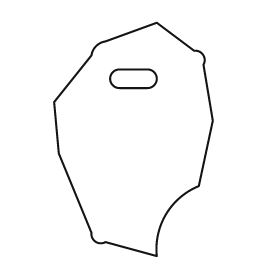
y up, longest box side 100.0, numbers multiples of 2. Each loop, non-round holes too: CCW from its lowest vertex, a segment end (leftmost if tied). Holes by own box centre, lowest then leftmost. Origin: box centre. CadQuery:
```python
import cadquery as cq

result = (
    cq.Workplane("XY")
    .moveTo(10.0, -50.0)
    .threePointArc((14.0, -32.0), (28.0, -20.0))
    .lineTo(34.0, 8.0)
    .lineTo(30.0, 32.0)
    .threePointArc((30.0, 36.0), (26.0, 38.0))
    .lineTo(10.0, 50.0)
    .lineTo(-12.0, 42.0)
    .threePointArc((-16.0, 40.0), (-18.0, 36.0))
    .lineTo(-34.0, 16.0)
    .lineTo(-32.0, -6.0)
    .lineTo(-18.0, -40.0)
    .threePointArc((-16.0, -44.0), (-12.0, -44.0))
    .close()
    .moveTo(-6.0, 22.0)
    .lineTo(6.0, 22.0)
    .threePointArc((10.0, 26.0), (6.0, 30.0))
    .lineTo(-6.0, 30.0)
    .threePointArc((-10.0, 26.0), (-6.0, 22.0))
    .close()
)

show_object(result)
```